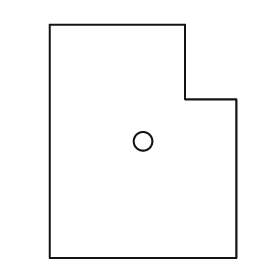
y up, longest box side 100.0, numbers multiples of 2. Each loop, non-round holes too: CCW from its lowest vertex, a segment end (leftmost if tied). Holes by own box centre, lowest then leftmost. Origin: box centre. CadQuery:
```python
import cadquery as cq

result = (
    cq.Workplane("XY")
    .moveTo(-40.0, -50.0)
    .lineTo(40.0, -50.0)
    .lineTo(40.0, 18.0)
    .lineTo(18.0, 18.0)
    .lineTo(18.0, 50.0)
    .lineTo(-40.0, 50.0)
    .close()
    .moveTo(0.0, 0.0)
    .circle(4.0)
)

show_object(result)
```